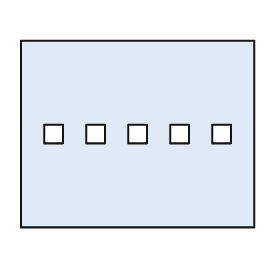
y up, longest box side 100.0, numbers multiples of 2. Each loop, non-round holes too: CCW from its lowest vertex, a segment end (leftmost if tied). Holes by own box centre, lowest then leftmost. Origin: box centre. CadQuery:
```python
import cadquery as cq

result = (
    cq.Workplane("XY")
    .moveTo(-50.0, -40.0)
    .lineTo(50.0, -40.0)
    .lineTo(50.0, 40.0)
    .lineTo(-50.0, 40.0)
    .close()
    .moveTo(-40.0, -4.0)
    .lineTo(-32.0, -4.0)
    .lineTo(-32.0, 4.0)
    .lineTo(-40.0, 4.0)
    .close()
    .moveTo(-22.0, -4.0)
    .lineTo(-14.0, -4.0)
    .lineTo(-14.0, 4.0)
    .lineTo(-22.0, 4.0)
    .close()
    .moveTo(-4.0, -4.0)
    .lineTo(4.0, -4.0)
    .lineTo(4.0, 4.0)
    .lineTo(-4.0, 4.0)
    .close()
    .moveTo(14.0, -4.0)
    .lineTo(22.0, -4.0)
    .lineTo(22.0, 4.0)
    .lineTo(14.0, 4.0)
    .close()
    .moveTo(32.0, -4.0)
    .lineTo(40.0, -4.0)
    .lineTo(40.0, 4.0)
    .lineTo(32.0, 4.0)
    .close()
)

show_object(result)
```